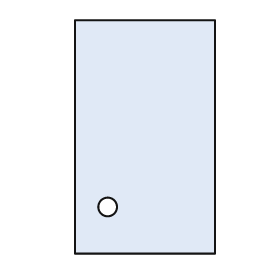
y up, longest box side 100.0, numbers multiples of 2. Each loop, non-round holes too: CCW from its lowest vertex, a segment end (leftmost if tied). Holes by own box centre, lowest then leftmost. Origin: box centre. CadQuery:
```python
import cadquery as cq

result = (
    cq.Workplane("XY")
    .moveTo(-30.0, -50.0)
    .lineTo(30.0, -50.0)
    .lineTo(30.0, 50.0)
    .lineTo(-30.0, 50.0)
    .close()
    .moveTo(-16.0, -30.0)
    .circle(4.0)
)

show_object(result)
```